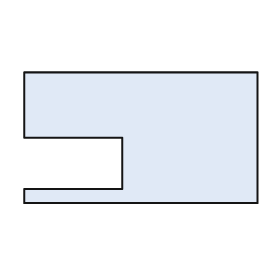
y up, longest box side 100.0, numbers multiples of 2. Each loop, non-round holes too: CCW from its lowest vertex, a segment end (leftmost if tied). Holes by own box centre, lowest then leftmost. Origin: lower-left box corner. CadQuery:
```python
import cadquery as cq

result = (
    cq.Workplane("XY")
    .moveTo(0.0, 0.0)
    .lineTo(100.0, 0.0)
    .lineTo(100.0, 56.0)
    .lineTo(0.0, 56.0)
    .lineTo(0.0, 28.0)
    .lineTo(42.0, 28.0)
    .lineTo(42.0, 6.0)
    .lineTo(0.0, 6.0)
    .close()
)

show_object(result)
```